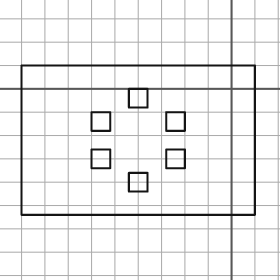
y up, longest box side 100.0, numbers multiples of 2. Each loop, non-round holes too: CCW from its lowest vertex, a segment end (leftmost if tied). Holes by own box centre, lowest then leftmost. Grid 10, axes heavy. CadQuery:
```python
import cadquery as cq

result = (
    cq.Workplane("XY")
    .moveTo(-90.0, -54.0)
    .lineTo(10.0, -54.0)
    .lineTo(10.0, 10.0)
    .lineTo(-90.0, 10.0)
    .close()
    .moveTo(-44.0, -44.0)
    .lineTo(-36.0, -44.0)
    .lineTo(-36.0, -36.0)
    .lineTo(-44.0, -36.0)
    .close()
    .moveTo(-60.0, -34.0)
    .lineTo(-52.0, -34.0)
    .lineTo(-52.0, -26.0)
    .lineTo(-60.0, -26.0)
    .close()
    .moveTo(-28.0, -34.0)
    .lineTo(-20.0, -34.0)
    .lineTo(-20.0, -26.0)
    .lineTo(-28.0, -26.0)
    .close()
    .moveTo(-60.0, -18.0)
    .lineTo(-52.0, -18.0)
    .lineTo(-52.0, -10.0)
    .lineTo(-60.0, -10.0)
    .close()
    .moveTo(-28.0, -18.0)
    .lineTo(-20.0, -18.0)
    .lineTo(-20.0, -10.0)
    .lineTo(-28.0, -10.0)
    .close()
    .moveTo(-44.0, -8.0)
    .lineTo(-36.0, -8.0)
    .lineTo(-36.0, 0.0)
    .lineTo(-44.0, 0.0)
    .close()
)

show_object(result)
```